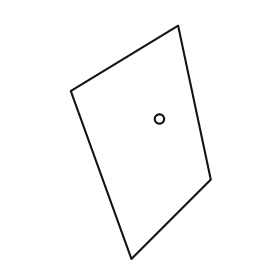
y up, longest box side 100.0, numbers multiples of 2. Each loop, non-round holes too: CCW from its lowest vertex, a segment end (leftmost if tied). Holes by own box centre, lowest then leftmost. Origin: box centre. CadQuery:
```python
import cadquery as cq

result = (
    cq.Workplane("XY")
    .moveTo(-4.0, -50.0)
    .lineTo(30.0, -16.0)
    .lineTo(16.0, 50.0)
    .lineTo(-30.0, 22.0)
    .close()
    .moveTo(8.0, 10.0)
    .circle(2.0)
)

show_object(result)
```